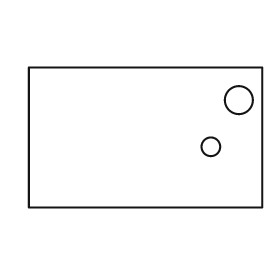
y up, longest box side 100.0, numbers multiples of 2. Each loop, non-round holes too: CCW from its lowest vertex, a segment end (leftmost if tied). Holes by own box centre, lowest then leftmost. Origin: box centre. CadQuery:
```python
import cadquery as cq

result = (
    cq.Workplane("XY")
    .moveTo(-50.0, -30.0)
    .lineTo(50.0, -30.0)
    .lineTo(50.0, 30.0)
    .lineTo(-50.0, 30.0)
    .close()
    .moveTo(28.0, -4.0)
    .circle(4.0)
    .moveTo(40.0, 16.0)
    .circle(6.0)
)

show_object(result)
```